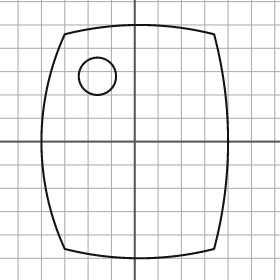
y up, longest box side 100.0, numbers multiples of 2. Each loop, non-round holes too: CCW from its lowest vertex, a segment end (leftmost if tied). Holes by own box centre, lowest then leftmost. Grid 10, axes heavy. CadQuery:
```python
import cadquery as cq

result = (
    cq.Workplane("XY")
    .moveTo(-30.0, -46.0)
    .threePointArc((2.0, -50.0), (34.0, -46.0))
    .threePointArc((40.0, 0.0), (34.0, 46.0))
    .threePointArc((2.0, 50.0), (-30.0, 46.0))
    .threePointArc((-40.0, 0.0), (-30.0, -46.0))
    .close()
    .moveTo(-16.0, 28.0)
    .circle(8.0)
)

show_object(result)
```